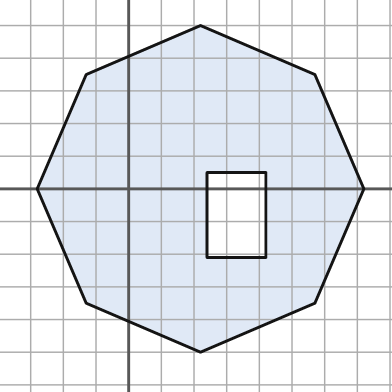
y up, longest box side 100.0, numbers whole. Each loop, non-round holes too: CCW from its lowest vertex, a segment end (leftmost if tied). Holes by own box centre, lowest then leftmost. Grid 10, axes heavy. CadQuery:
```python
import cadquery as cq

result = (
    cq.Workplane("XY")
    .moveTo(22.0, -50.0)
    .lineTo(57.0, -35.0)
    .lineTo(72.0, 0.0)
    .lineTo(57.0, 35.0)
    .lineTo(22.0, 50.0)
    .lineTo(-13.0, 35.0)
    .lineTo(-28.0, 0.0)
    .lineTo(-13.0, -35.0)
    .close()
    .moveTo(24.0, -21.0)
    .lineTo(42.0, -21.0)
    .lineTo(42.0, 5.0)
    .lineTo(24.0, 5.0)
    .close()
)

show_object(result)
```